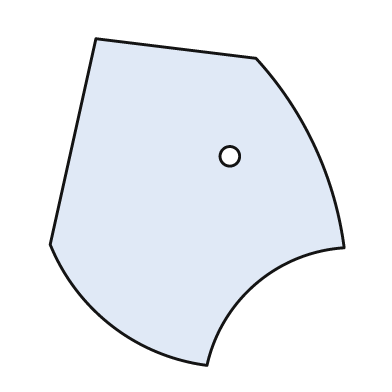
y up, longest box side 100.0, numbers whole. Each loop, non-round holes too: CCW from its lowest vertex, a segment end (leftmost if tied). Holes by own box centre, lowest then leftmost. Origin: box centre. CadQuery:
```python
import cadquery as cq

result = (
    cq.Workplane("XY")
    .moveTo(3.0, -50.0)
    .threePointArc((18.0, -25.0), (45.0, -14.0))
    .threePointArc((36.0, 17.0), (18.0, 44.0))
    .lineTo(-31.0, 50.0)
    .lineTo(-45.0, -13.0)
    .threePointArc((-26.0, -38.0), (3.0, -50.0))
    .close()
    .moveTo(10.0, 14.0)
    .circle(3.0)
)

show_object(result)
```